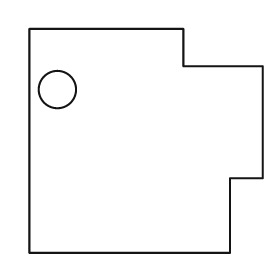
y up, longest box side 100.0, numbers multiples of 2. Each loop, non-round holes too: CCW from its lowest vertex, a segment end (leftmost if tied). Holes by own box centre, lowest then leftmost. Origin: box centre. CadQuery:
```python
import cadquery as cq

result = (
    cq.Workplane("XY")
    .moveTo(-50.0, -48.0)
    .lineTo(36.0, -48.0)
    .lineTo(36.0, -16.0)
    .lineTo(50.0, -16.0)
    .lineTo(50.0, 32.0)
    .lineTo(16.0, 32.0)
    .lineTo(16.0, 48.0)
    .lineTo(-50.0, 48.0)
    .close()
    .moveTo(-38.0, 22.0)
    .circle(8.0)
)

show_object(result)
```